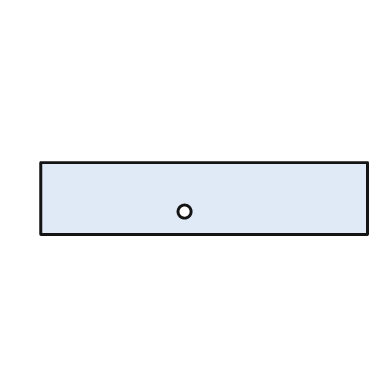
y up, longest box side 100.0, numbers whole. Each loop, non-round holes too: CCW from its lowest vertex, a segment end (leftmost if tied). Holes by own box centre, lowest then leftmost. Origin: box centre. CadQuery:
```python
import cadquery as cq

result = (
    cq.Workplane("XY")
    .moveTo(-50.0, -11.0)
    .lineTo(50.0, -11.0)
    .lineTo(50.0, 11.0)
    .lineTo(-50.0, 11.0)
    .close()
    .moveTo(-6.0, -4.0)
    .circle(2.0)
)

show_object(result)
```